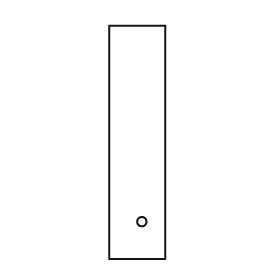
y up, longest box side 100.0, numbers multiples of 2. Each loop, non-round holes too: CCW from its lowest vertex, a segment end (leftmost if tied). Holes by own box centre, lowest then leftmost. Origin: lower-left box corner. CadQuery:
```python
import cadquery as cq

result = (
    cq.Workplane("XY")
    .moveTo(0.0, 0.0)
    .lineTo(24.0, 0.0)
    .lineTo(24.0, 100.0)
    .lineTo(0.0, 100.0)
    .close()
    .moveTo(14.0, 16.0)
    .circle(2.0)
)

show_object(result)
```